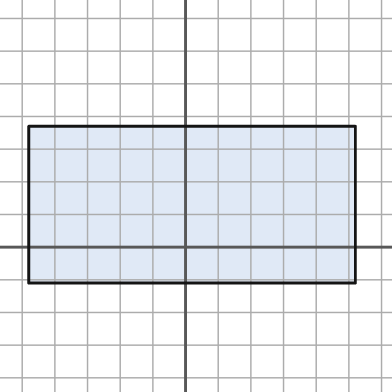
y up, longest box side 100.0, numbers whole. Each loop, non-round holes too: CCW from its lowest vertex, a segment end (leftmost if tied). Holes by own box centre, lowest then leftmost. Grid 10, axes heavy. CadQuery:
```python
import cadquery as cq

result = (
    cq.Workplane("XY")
    .moveTo(-48.0, -11.0)
    .lineTo(52.0, -11.0)
    .lineTo(52.0, 37.0)
    .lineTo(-48.0, 37.0)
    .close()
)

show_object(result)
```